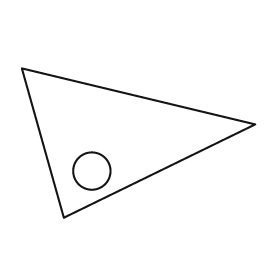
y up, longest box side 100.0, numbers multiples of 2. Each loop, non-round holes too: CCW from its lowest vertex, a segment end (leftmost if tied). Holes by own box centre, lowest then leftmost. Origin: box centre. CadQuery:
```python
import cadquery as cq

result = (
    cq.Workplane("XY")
    .moveTo(-32.0, -32.0)
    .lineTo(50.0, 8.0)
    .lineTo(-50.0, 32.0)
    .close()
    .moveTo(-20.0, -12.0)
    .circle(8.0)
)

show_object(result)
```